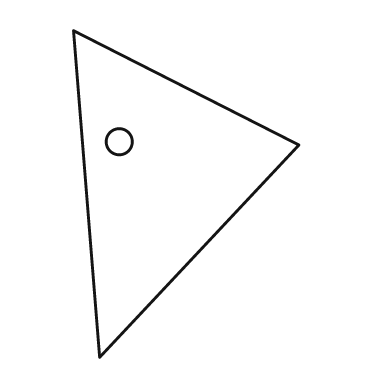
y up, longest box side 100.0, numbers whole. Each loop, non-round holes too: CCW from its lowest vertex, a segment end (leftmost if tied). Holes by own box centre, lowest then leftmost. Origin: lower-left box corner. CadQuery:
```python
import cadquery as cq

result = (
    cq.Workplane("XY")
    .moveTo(8.0, 0.0)
    .lineTo(69.0, 65.0)
    .lineTo(0.0, 100.0)
    .close()
    .moveTo(14.0, 66.0)
    .circle(4.0)
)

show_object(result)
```